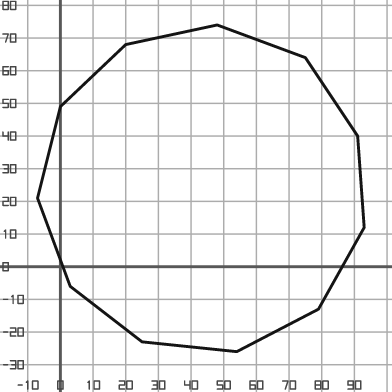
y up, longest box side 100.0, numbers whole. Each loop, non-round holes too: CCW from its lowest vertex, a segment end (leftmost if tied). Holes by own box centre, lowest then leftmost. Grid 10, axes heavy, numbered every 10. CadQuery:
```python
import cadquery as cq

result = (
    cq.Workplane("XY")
    .moveTo(54.0, -26.0)
    .lineTo(79.0, -13.0)
    .lineTo(93.0, 12.0)
    .lineTo(91.0, 40.0)
    .lineTo(75.0, 64.0)
    .lineTo(48.0, 74.0)
    .lineTo(20.0, 68.0)
    .lineTo(0.0, 49.0)
    .lineTo(-7.0, 21.0)
    .lineTo(3.0, -6.0)
    .lineTo(25.0, -23.0)
    .close()
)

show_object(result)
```